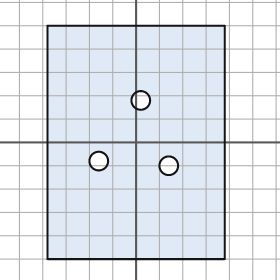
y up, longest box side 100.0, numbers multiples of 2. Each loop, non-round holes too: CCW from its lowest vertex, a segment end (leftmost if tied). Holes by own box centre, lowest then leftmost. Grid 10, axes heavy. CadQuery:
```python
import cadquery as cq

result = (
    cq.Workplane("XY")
    .moveTo(-38.0, -50.0)
    .lineTo(38.0, -50.0)
    .lineTo(38.0, 50.0)
    .lineTo(-38.0, 50.0)
    .close()
    .moveTo(14.0, -10.0)
    .circle(4.0)
    .moveTo(-16.0, -8.0)
    .circle(4.0)
    .moveTo(2.0, 18.0)
    .circle(4.0)
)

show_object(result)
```